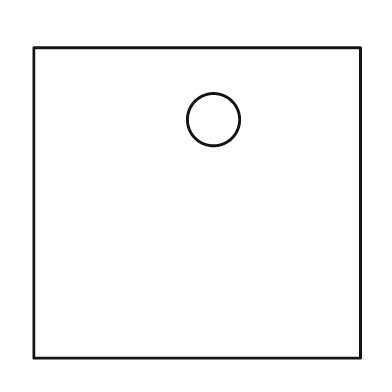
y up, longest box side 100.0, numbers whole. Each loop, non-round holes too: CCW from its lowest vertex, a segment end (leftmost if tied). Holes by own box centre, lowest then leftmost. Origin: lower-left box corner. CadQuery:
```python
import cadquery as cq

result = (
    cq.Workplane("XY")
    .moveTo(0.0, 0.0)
    .lineTo(100.0, 0.0)
    .lineTo(100.0, 95.0)
    .lineTo(0.0, 95.0)
    .close()
    .moveTo(55.0, 73.0)
    .circle(8.0)
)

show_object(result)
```